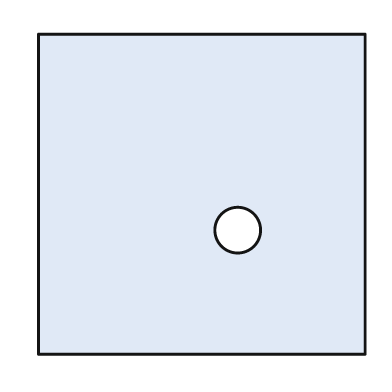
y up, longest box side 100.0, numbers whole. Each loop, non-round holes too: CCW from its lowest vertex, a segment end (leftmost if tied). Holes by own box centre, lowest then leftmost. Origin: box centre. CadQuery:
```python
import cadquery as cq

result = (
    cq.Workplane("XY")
    .moveTo(-50.0, -49.0)
    .lineTo(50.0, -49.0)
    .lineTo(50.0, 49.0)
    .lineTo(-50.0, 49.0)
    .close()
    .moveTo(11.0, -11.0)
    .circle(7.0)
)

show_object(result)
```